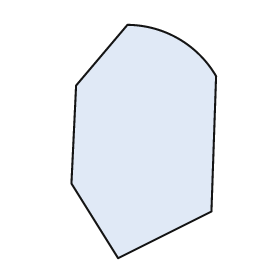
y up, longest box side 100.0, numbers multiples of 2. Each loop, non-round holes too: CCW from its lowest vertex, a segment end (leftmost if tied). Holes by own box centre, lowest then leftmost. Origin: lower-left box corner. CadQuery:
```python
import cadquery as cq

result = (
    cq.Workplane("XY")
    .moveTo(20.0, 0.0)
    .lineTo(60.0, 20.0)
    .lineTo(62.0, 78.0)
    .threePointArc((46.0, 94.0), (24.0, 100.0))
    .lineTo(2.0, 74.0)
    .lineTo(0.0, 32.0)
    .close()
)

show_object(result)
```